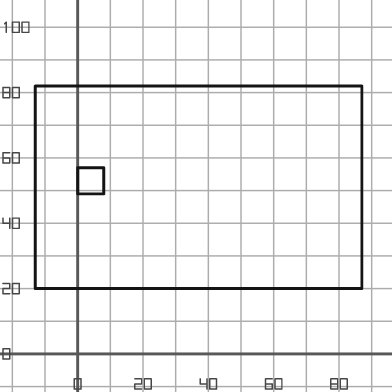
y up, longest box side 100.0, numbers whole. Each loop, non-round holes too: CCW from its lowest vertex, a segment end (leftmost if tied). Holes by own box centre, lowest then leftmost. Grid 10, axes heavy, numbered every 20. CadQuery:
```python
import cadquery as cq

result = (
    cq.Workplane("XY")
    .moveTo(-13.0, 20.0)
    .lineTo(87.0, 20.0)
    .lineTo(87.0, 82.0)
    .lineTo(-13.0, 82.0)
    .close()
    .moveTo(0.0, 49.0)
    .lineTo(8.0, 49.0)
    .lineTo(8.0, 57.0)
    .lineTo(0.0, 57.0)
    .close()
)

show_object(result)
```